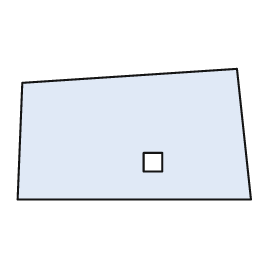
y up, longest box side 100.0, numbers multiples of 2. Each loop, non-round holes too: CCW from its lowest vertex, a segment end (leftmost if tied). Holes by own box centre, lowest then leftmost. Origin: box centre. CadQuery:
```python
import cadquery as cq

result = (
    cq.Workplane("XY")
    .moveTo(-50.0, -28.0)
    .lineTo(50.0, -28.0)
    .lineTo(44.0, 28.0)
    .lineTo(-48.0, 22.0)
    .close()
    .moveTo(4.0, -16.0)
    .lineTo(12.0, -16.0)
    .lineTo(12.0, -8.0)
    .lineTo(4.0, -8.0)
    .close()
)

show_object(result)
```